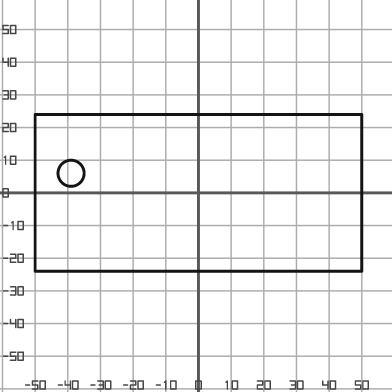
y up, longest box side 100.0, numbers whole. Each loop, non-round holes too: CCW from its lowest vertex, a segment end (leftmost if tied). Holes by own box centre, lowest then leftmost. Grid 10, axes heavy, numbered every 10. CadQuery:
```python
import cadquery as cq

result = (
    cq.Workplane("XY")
    .moveTo(-50.0, -24.0)
    .lineTo(50.0, -24.0)
    .lineTo(50.0, 24.0)
    .lineTo(-50.0, 24.0)
    .close()
    .moveTo(-39.0, 6.0)
    .circle(4.0)
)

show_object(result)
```